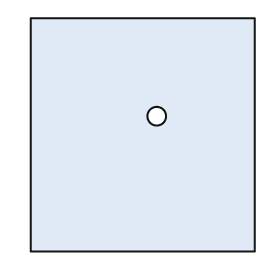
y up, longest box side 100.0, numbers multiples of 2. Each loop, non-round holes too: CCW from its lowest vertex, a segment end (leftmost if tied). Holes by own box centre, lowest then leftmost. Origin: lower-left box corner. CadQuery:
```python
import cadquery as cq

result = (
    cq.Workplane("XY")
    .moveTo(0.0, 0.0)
    .lineTo(96.0, 0.0)
    .lineTo(96.0, 100.0)
    .lineTo(0.0, 100.0)
    .close()
    .moveTo(54.0, 58.0)
    .circle(4.0)
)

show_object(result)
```